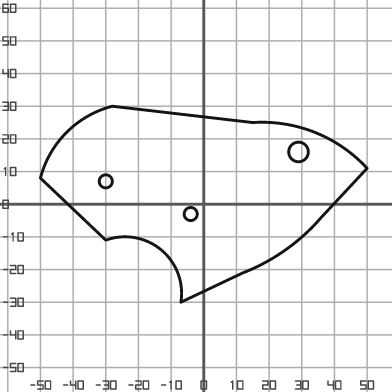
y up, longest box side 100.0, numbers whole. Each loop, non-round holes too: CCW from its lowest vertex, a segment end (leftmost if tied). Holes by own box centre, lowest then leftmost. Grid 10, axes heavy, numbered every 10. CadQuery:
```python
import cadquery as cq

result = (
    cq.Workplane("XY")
    .moveTo(-7.0, -30.0)
    .lineTo(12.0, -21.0)
    .threePointArc((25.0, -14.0), (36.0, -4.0))
    .lineTo(50.0, 11.0)
    .threePointArc((34.0, 22.0), (15.0, 25.0))
    .lineTo(-28.0, 30.0)
    .threePointArc((-42.0, 22.0), (-50.0, 8.0))
    .lineTo(-30.0, -11.0)
    .threePointArc((-13.0, -14.0), (-7.0, -30.0))
    .close()
    .moveTo(-4.0, -3.0)
    .circle(2.0)
    .moveTo(-30.0, 7.0)
    .circle(2.0)
    .moveTo(29.0, 16.0)
    .circle(3.0)
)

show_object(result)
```